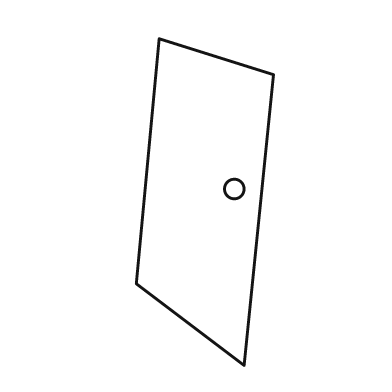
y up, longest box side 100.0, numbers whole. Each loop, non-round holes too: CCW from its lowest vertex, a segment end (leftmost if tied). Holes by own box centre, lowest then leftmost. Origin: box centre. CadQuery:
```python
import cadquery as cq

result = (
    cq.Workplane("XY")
    .moveTo(12.0, -50.0)
    .lineTo(21.0, 39.0)
    .lineTo(-14.0, 50.0)
    .lineTo(-21.0, -25.0)
    .close()
    .moveTo(9.0, 4.0)
    .circle(3.0)
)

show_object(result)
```